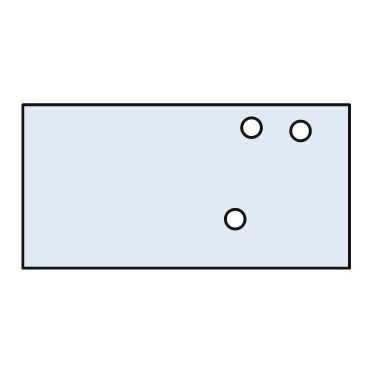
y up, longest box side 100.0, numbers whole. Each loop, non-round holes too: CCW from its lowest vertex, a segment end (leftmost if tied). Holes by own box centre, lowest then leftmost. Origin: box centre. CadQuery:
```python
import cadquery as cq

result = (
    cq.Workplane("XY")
    .moveTo(-50.0, -25.0)
    .lineTo(50.0, -25.0)
    .lineTo(50.0, 25.0)
    .lineTo(-50.0, 25.0)
    .close()
    .moveTo(15.0, -10.0)
    .circle(3.0)
    .moveTo(35.0, 17.0)
    .circle(3.0)
    .moveTo(20.0, 18.0)
    .circle(3.0)
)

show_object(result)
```